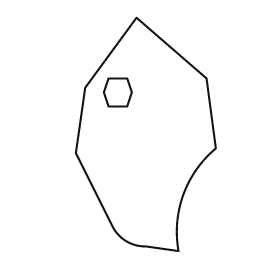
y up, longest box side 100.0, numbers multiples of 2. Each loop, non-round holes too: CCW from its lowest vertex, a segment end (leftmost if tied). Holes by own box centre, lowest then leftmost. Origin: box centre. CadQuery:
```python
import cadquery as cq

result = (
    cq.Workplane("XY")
    .moveTo(14.0, -50.0)
    .threePointArc((16.0, -26.0), (30.0, -6.0))
    .lineTo(26.0, 24.0)
    .lineTo(-4.0, 50.0)
    .lineTo(-26.0, 20.0)
    .lineTo(-30.0, -8.0)
    .lineTo(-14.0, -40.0)
    .threePointArc((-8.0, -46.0), (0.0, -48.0))
    .close()
    .moveTo(-16.0, 12.0)
    .lineTo(-8.0, 12.0)
    .lineTo(-6.0, 18.0)
    .lineTo(-8.0, 24.0)
    .lineTo(-16.0, 24.0)
    .lineTo(-18.0, 18.0)
    .close()
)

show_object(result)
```